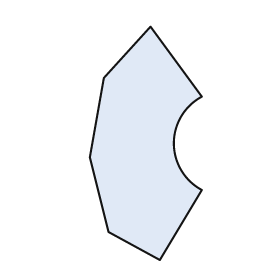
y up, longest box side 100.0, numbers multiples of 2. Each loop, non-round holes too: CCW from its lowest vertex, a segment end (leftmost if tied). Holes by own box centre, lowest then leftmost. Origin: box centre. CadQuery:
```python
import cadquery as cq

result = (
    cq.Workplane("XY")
    .moveTo(6.0, -50.0)
    .lineTo(24.0, -20.0)
    .threePointArc((12.0, 0.0), (24.0, 20.0))
    .lineTo(2.0, 50.0)
    .lineTo(-18.0, 28.0)
    .lineTo(-24.0, -6.0)
    .lineTo(-16.0, -38.0)
    .close()
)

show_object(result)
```